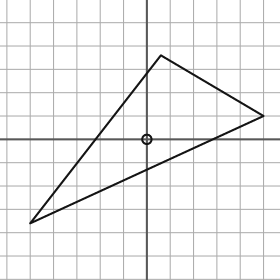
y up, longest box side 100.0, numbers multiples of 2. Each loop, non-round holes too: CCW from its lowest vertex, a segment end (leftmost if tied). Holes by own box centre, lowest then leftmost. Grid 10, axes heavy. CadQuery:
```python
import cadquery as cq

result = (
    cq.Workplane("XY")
    .moveTo(-50.0, -36.0)
    .lineTo(50.0, 10.0)
    .lineTo(6.0, 36.0)
    .close()
    .moveTo(0.0, 0.0)
    .circle(2.0)
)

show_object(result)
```